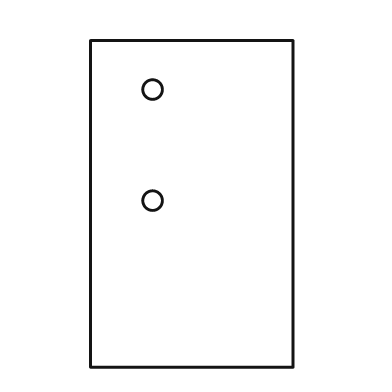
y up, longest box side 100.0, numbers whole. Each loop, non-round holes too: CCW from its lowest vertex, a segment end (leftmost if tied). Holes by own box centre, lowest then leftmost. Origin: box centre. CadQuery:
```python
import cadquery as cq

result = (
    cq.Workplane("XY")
    .moveTo(-31.0, -50.0)
    .lineTo(31.0, -50.0)
    .lineTo(31.0, 50.0)
    .lineTo(-31.0, 50.0)
    .close()
    .moveTo(-12.0, 1.0)
    .circle(3.0)
    .moveTo(-12.0, 35.0)
    .circle(3.0)
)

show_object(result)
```